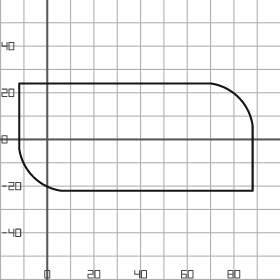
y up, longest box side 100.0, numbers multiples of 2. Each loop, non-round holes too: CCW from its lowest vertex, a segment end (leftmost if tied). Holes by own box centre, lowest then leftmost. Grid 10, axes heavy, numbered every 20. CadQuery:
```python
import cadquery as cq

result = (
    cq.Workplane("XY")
    .moveTo(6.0, -22.0)
    .lineTo(88.0, -22.0)
    .lineTo(88.0, 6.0)
    .threePointArc((82.0, 18.0), (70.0, 24.0))
    .lineTo(-12.0, 24.0)
    .lineTo(-12.0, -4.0)
    .threePointArc((-6.0, -16.0), (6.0, -22.0))
    .close()
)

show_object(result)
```